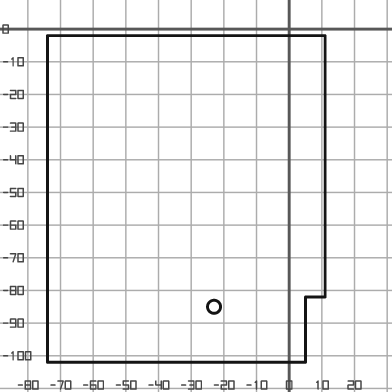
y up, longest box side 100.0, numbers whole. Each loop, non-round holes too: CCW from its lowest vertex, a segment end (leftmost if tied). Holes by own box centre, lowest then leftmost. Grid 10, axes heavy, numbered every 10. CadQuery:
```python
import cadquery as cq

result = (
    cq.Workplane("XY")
    .moveTo(-74.0, -102.0)
    .lineTo(5.0, -102.0)
    .lineTo(5.0, -82.0)
    .lineTo(11.0, -82.0)
    .lineTo(11.0, -2.0)
    .lineTo(-74.0, -2.0)
    .close()
    .moveTo(-23.0, -85.0)
    .circle(2.0)
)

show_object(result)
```